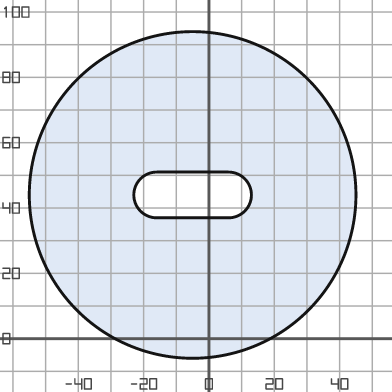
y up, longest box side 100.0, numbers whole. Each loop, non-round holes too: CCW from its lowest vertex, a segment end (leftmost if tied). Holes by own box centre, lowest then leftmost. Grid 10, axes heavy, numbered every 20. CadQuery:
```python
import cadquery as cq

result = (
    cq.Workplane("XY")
    .moveTo(-5.0, 44.0)
    .circle(50.0)
    .moveTo(-16.0, 37.0)
    .lineTo(6.0, 37.0)
    .threePointArc((13.0, 44.0), (6.0, 51.0))
    .lineTo(-16.0, 51.0)
    .threePointArc((-23.0, 44.0), (-16.0, 37.0))
    .close()
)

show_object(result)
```